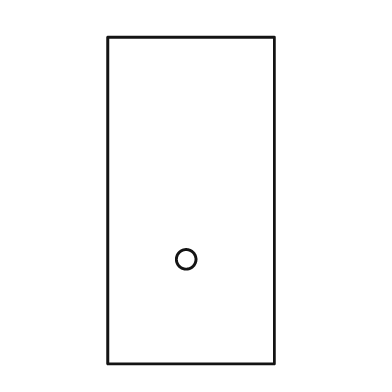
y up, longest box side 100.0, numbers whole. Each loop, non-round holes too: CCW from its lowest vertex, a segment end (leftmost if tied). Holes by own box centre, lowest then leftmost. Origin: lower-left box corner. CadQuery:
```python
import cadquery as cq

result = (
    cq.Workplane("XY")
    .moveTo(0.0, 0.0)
    .lineTo(51.0, 0.0)
    .lineTo(51.0, 100.0)
    .lineTo(0.0, 100.0)
    .close()
    .moveTo(24.0, 32.0)
    .circle(3.0)
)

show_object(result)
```